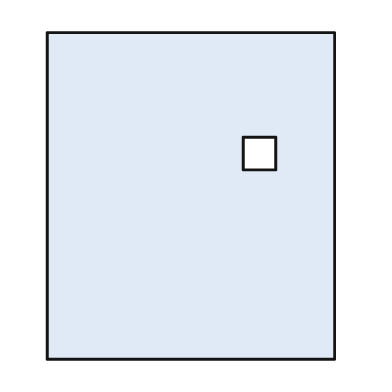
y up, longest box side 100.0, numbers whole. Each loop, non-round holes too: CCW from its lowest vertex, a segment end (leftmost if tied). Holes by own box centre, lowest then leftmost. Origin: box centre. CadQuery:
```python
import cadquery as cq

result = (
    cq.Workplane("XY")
    .moveTo(-44.0, -50.0)
    .lineTo(44.0, -50.0)
    .lineTo(44.0, 50.0)
    .lineTo(-44.0, 50.0)
    .close()
    .moveTo(16.0, 8.0)
    .lineTo(26.0, 8.0)
    .lineTo(26.0, 18.0)
    .lineTo(16.0, 18.0)
    .close()
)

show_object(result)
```